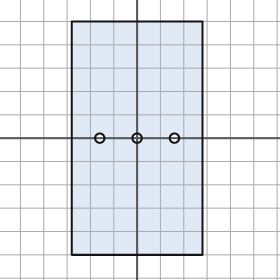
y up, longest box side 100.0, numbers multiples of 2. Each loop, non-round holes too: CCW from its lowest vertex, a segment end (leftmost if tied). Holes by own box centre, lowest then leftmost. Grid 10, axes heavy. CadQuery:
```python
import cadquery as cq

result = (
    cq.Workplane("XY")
    .moveTo(-28.0, -50.0)
    .lineTo(28.0, -50.0)
    .lineTo(28.0, 50.0)
    .lineTo(-28.0, 50.0)
    .close()
    .moveTo(-16.0, 0.0)
    .circle(2.0)
    .moveTo(0.0, 0.0)
    .circle(2.0)
    .moveTo(16.0, 0.0)
    .circle(2.0)
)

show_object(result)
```